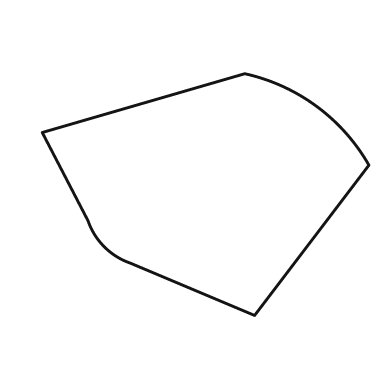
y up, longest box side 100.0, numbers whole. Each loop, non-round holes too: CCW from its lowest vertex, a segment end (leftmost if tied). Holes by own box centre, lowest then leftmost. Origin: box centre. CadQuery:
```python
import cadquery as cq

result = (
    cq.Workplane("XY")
    .moveTo(15.0, -37.0)
    .lineTo(50.0, 9.0)
    .threePointArc((34.0, 27.0), (12.0, 37.0))
    .lineTo(-50.0, 19.0)
    .lineTo(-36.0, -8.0)
    .threePointArc((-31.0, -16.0), (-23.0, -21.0))
    .close()
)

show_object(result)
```